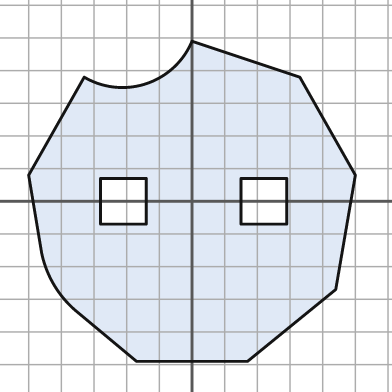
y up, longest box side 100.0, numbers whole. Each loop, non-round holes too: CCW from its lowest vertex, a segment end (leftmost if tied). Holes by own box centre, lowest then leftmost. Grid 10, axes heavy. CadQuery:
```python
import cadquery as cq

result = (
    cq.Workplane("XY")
    .moveTo(-17.0, -49.0)
    .lineTo(17.0, -49.0)
    .lineTo(44.0, -27.0)
    .lineTo(50.0, 8.0)
    .lineTo(33.0, 38.0)
    .lineTo(0.0, 49.0)
    .threePointArc((-14.0, 36.0), (-33.0, 38.0))
    .lineTo(-50.0, 8.0)
    .lineTo(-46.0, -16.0)
    .threePointArc((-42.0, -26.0), (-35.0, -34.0))
    .close()
    .moveTo(-28.0, -7.0)
    .lineTo(-14.0, -7.0)
    .lineTo(-14.0, 7.0)
    .lineTo(-28.0, 7.0)
    .close()
    .moveTo(15.0, -7.0)
    .lineTo(29.0, -7.0)
    .lineTo(29.0, 7.0)
    .lineTo(15.0, 7.0)
    .close()
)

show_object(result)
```